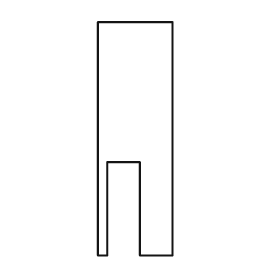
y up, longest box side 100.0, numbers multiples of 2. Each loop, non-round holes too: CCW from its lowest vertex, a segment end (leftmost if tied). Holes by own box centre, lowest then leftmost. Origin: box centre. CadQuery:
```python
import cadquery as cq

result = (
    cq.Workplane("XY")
    .moveTo(-16.0, -50.0)
    .lineTo(-12.0, -50.0)
    .lineTo(-12.0, -10.0)
    .lineTo(2.0, -10.0)
    .lineTo(2.0, -50.0)
    .lineTo(16.0, -50.0)
    .lineTo(16.0, 50.0)
    .lineTo(-16.0, 50.0)
    .close()
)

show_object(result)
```